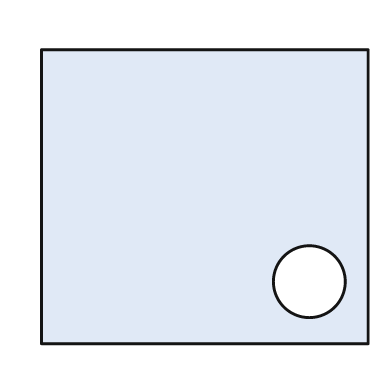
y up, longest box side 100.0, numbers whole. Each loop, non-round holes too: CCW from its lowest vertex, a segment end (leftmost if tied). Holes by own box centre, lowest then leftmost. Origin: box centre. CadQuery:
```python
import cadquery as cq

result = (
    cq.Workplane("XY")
    .moveTo(-50.0, -45.0)
    .lineTo(50.0, -45.0)
    .lineTo(50.0, 45.0)
    .lineTo(-50.0, 45.0)
    .close()
    .moveTo(32.0, -26.0)
    .circle(11.0)
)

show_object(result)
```